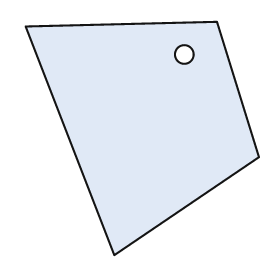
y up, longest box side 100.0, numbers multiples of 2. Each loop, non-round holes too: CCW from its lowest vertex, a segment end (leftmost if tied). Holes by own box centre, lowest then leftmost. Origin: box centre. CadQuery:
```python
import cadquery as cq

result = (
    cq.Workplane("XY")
    .moveTo(-12.0, -50.0)
    .lineTo(50.0, -8.0)
    .lineTo(32.0, 50.0)
    .lineTo(-50.0, 48.0)
    .close()
    .moveTo(18.0, 36.0)
    .circle(4.0)
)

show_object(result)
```